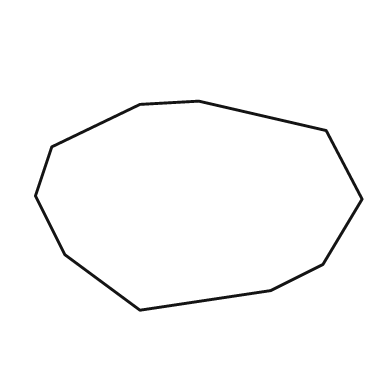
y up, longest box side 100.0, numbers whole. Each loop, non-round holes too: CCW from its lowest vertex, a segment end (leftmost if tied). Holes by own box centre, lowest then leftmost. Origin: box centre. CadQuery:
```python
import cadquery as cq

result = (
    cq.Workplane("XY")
    .moveTo(-18.0, -32.0)
    .lineTo(22.0, -26.0)
    .lineTo(38.0, -18.0)
    .lineTo(50.0, 2.0)
    .lineTo(39.0, 23.0)
    .lineTo(0.0, 32.0)
    .lineTo(-18.0, 31.0)
    .lineTo(-45.0, 18.0)
    .lineTo(-50.0, 3.0)
    .lineTo(-41.0, -15.0)
    .close()
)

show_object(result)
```